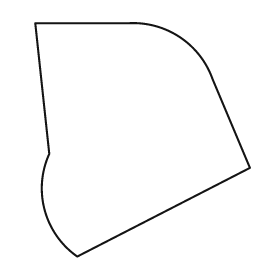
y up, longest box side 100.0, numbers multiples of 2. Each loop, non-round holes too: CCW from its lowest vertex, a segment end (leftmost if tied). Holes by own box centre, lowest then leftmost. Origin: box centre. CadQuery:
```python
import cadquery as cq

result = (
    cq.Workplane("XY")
    .moveTo(-28.0, -50.0)
    .lineTo(46.0, -12.0)
    .lineTo(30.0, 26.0)
    .threePointArc((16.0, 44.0), (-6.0, 50.0))
    .lineTo(-46.0, 50.0)
    .lineTo(-40.0, -6.0)
    .threePointArc((-42.0, -30.0), (-28.0, -50.0))
    .close()
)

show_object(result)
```